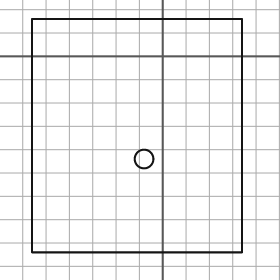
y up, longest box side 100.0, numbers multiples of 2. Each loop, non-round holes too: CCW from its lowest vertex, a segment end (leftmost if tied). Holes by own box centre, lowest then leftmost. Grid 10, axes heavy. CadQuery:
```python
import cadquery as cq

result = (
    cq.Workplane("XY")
    .moveTo(-56.0, -84.0)
    .lineTo(34.0, -84.0)
    .lineTo(34.0, 16.0)
    .lineTo(-56.0, 16.0)
    .close()
    .moveTo(-8.0, -44.0)
    .circle(4.0)
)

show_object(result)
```